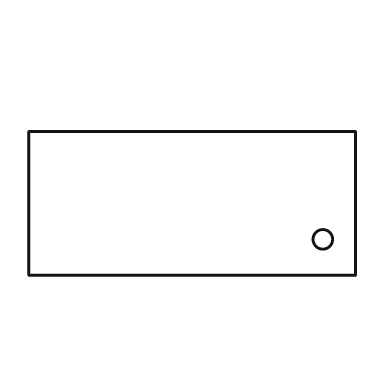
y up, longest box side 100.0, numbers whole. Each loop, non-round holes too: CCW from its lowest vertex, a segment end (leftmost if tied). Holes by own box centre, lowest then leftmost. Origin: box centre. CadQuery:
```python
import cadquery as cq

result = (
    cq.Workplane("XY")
    .moveTo(-50.0, -22.0)
    .lineTo(50.0, -22.0)
    .lineTo(50.0, 22.0)
    .lineTo(-50.0, 22.0)
    .close()
    .moveTo(40.0, -11.0)
    .circle(3.0)
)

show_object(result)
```